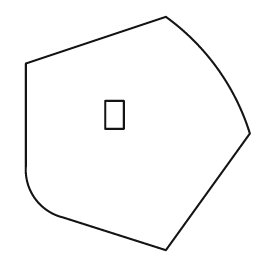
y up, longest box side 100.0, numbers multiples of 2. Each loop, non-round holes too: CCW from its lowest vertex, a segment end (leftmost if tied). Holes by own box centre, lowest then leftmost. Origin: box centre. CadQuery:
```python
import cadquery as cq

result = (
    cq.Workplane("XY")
    .moveTo(12.0, -50.0)
    .lineTo(48.0, 0.0)
    .threePointArc((34.0, 28.0), (12.0, 50.0))
    .lineTo(-48.0, 30.0)
    .lineTo(-48.0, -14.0)
    .threePointArc((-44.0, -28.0), (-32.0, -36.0))
    .close()
    .moveTo(-14.0, 2.0)
    .lineTo(-6.0, 2.0)
    .lineTo(-6.0, 14.0)
    .lineTo(-14.0, 14.0)
    .close()
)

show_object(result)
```